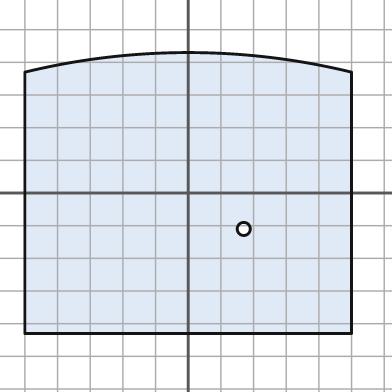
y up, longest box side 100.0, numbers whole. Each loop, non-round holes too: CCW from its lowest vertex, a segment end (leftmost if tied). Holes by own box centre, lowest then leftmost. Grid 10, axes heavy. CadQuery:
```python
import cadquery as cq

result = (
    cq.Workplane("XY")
    .moveTo(-50.0, -43.0)
    .lineTo(50.0, -43.0)
    .lineTo(50.0, 37.0)
    .threePointArc((0.0, 43.0), (-50.0, 37.0))
    .close()
    .moveTo(17.0, -11.0)
    .circle(2.0)
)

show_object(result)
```